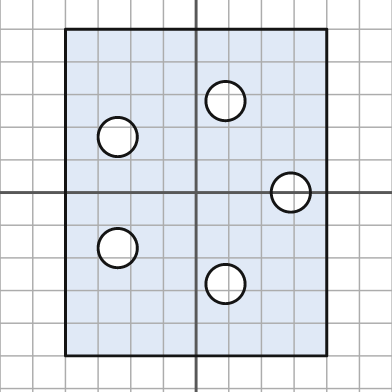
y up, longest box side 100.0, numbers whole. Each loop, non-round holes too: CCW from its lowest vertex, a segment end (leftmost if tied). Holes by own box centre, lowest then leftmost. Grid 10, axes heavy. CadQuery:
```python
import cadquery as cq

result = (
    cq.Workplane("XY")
    .moveTo(-40.0, -50.0)
    .lineTo(40.0, -50.0)
    .lineTo(40.0, 50.0)
    .lineTo(-40.0, 50.0)
    .close()
    .moveTo(9.0, -28.0)
    .circle(6.0)
    .moveTo(-24.0, -17.0)
    .circle(6.0)
    .moveTo(29.0, 0.0)
    .circle(6.0)
    .moveTo(-24.0, 17.0)
    .circle(6.0)
    .moveTo(9.0, 28.0)
    .circle(6.0)
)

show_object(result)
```